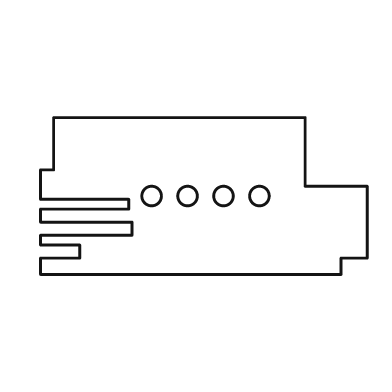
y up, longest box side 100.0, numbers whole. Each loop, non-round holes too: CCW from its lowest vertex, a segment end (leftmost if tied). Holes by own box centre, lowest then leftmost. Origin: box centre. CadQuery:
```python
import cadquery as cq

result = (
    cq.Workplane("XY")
    .moveTo(-50.0, -24.0)
    .lineTo(42.0, -24.0)
    .lineTo(42.0, -19.0)
    .lineTo(50.0, -19.0)
    .lineTo(50.0, 3.0)
    .lineTo(31.0, 3.0)
    .lineTo(31.0, 24.0)
    .lineTo(-46.0, 24.0)
    .lineTo(-46.0, 8.0)
    .lineTo(-50.0, 8.0)
    .lineTo(-50.0, -1.0)
    .lineTo(-23.0, -1.0)
    .lineTo(-23.0, -4.0)
    .lineTo(-50.0, -4.0)
    .lineTo(-50.0, -8.0)
    .lineTo(-22.0, -8.0)
    .lineTo(-22.0, -12.0)
    .lineTo(-50.0, -12.0)
    .lineTo(-50.0, -15.0)
    .lineTo(-38.0, -15.0)
    .lineTo(-38.0, -19.0)
    .lineTo(-50.0, -19.0)
    .close()
    .moveTo(-16.0, 0.0)
    .circle(3.0)
    .moveTo(-5.0, 0.0)
    .circle(3.0)
    .moveTo(6.0, 0.0)
    .circle(3.0)
    .moveTo(17.0, 0.0)
    .circle(3.0)
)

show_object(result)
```